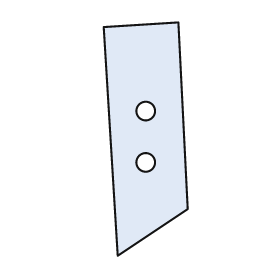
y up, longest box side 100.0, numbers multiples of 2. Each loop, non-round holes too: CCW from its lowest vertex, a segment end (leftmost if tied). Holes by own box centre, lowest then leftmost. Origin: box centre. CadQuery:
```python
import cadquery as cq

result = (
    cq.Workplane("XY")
    .moveTo(-12.0, -50.0)
    .lineTo(18.0, -30.0)
    .lineTo(14.0, 50.0)
    .lineTo(-18.0, 48.0)
    .close()
    .moveTo(0.0, -10.0)
    .circle(4.0)
    .moveTo(0.0, 12.0)
    .circle(4.0)
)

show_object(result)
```